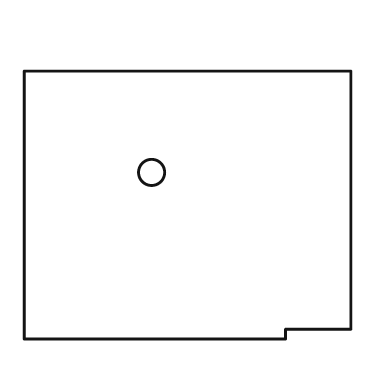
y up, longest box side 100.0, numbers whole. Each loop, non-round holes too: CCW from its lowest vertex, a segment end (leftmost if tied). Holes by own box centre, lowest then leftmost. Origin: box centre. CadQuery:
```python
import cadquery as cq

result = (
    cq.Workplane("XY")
    .moveTo(-50.0, -41.0)
    .lineTo(30.0, -41.0)
    .lineTo(30.0, -38.0)
    .lineTo(50.0, -38.0)
    .lineTo(50.0, 41.0)
    .lineTo(-50.0, 41.0)
    .close()
    .moveTo(-11.0, 10.0)
    .circle(4.0)
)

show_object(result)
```